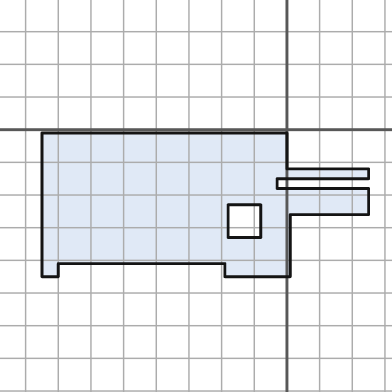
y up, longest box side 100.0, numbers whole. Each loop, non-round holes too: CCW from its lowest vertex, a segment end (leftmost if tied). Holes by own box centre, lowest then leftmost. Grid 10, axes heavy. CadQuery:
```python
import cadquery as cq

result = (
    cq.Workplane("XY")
    .moveTo(-75.0, -45.0)
    .lineTo(-70.0, -45.0)
    .lineTo(-70.0, -41.0)
    .lineTo(-19.0, -41.0)
    .lineTo(-19.0, -45.0)
    .lineTo(1.0, -45.0)
    .lineTo(1.0, -26.0)
    .lineTo(25.0, -26.0)
    .lineTo(25.0, -18.0)
    .lineTo(-3.0, -18.0)
    .lineTo(-3.0, -15.0)
    .lineTo(25.0, -15.0)
    .lineTo(25.0, -12.0)
    .lineTo(0.0, -12.0)
    .lineTo(0.0, -1.0)
    .lineTo(-75.0, -1.0)
    .close()
    .moveTo(-18.0, -33.0)
    .lineTo(-8.0, -33.0)
    .lineTo(-8.0, -23.0)
    .lineTo(-18.0, -23.0)
    .close()
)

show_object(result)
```